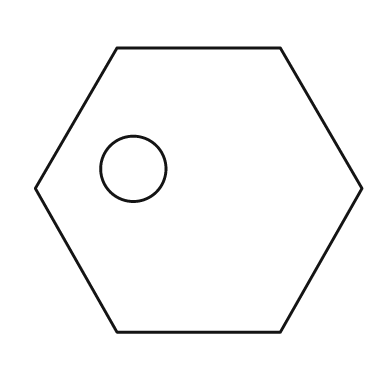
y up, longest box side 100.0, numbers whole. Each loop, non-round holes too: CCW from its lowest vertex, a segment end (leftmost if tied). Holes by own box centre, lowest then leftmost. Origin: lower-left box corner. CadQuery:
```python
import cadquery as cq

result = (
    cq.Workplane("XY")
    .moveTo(25.0, 0.0)
    .lineTo(75.0, 0.0)
    .lineTo(100.0, 44.0)
    .lineTo(75.0, 87.0)
    .lineTo(25.0, 87.0)
    .lineTo(0.0, 44.0)
    .close()
    .moveTo(30.0, 50.0)
    .circle(10.0)
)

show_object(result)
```